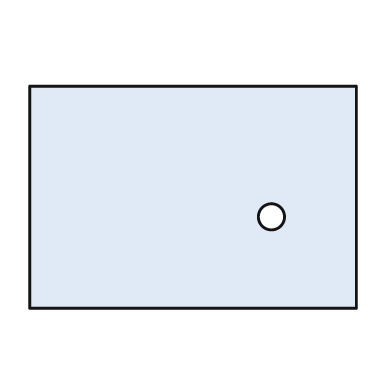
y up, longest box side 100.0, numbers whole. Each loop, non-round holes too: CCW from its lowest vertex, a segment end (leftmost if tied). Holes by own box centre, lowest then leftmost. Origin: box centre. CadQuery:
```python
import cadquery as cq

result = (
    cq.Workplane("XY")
    .moveTo(-50.0, -34.0)
    .lineTo(50.0, -34.0)
    .lineTo(50.0, 34.0)
    .lineTo(-50.0, 34.0)
    .close()
    .moveTo(24.0, -6.0)
    .circle(4.0)
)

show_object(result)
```